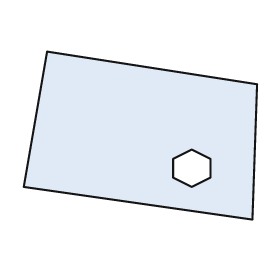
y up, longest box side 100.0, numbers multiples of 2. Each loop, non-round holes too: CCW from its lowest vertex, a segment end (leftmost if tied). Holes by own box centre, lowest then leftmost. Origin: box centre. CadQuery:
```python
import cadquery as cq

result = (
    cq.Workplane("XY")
    .moveTo(48.0, -36.0)
    .lineTo(50.0, 22.0)
    .lineTo(-40.0, 36.0)
    .lineTo(-50.0, -22.0)
    .close()
    .moveTo(22.0, -22.0)
    .lineTo(30.0, -18.0)
    .lineTo(30.0, -10.0)
    .lineTo(22.0, -6.0)
    .lineTo(14.0, -10.0)
    .lineTo(14.0, -18.0)
    .close()
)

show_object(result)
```